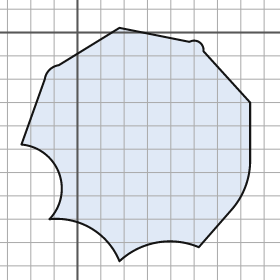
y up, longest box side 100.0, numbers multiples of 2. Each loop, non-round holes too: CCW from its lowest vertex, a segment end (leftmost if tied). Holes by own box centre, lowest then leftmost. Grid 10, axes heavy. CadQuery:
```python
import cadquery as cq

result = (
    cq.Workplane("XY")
    .moveTo(18.0, -98.0)
    .threePointArc((34.0, -90.0), (52.0, -92.0))
    .lineTo(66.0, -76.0)
    .threePointArc((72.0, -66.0), (74.0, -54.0))
    .lineTo(74.0, -30.0)
    .lineTo(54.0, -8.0)
    .threePointArc((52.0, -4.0), (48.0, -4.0))
    .lineTo(18.0, 2.0)
    .lineTo(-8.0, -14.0)
    .threePointArc((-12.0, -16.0), (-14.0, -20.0))
    .lineTo(-24.0, -48.0)
    .threePointArc((-8.0, -60.0), (-12.0, -80.0))
    .threePointArc((6.0, -84.0), (18.0, -98.0))
    .close()
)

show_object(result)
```